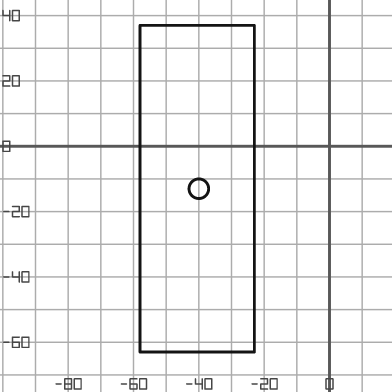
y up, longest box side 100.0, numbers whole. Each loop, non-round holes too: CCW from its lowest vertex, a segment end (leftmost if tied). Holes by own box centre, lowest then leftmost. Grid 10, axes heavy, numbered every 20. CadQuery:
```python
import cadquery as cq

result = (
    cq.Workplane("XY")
    .moveTo(-58.0, -63.0)
    .lineTo(-23.0, -63.0)
    .lineTo(-23.0, 37.0)
    .lineTo(-58.0, 37.0)
    .close()
    .moveTo(-40.0, -13.0)
    .circle(3.0)
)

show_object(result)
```